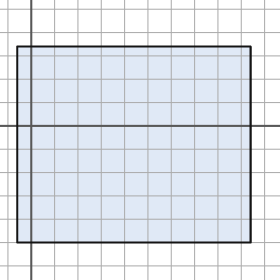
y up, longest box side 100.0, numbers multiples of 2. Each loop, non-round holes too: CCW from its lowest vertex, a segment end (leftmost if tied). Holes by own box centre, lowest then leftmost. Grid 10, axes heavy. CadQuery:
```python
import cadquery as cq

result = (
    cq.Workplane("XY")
    .moveTo(-6.0, -50.0)
    .lineTo(94.0, -50.0)
    .lineTo(94.0, 34.0)
    .lineTo(-6.0, 34.0)
    .close()
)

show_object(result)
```